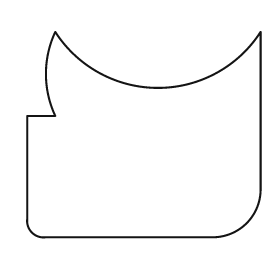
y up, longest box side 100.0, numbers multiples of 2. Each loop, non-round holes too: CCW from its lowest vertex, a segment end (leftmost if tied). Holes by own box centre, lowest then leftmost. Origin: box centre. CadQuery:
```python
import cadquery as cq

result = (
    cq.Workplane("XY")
    .moveTo(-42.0, -44.0)
    .lineTo(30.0, -44.0)
    .threePointArc((44.0, -38.0), (50.0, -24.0))
    .lineTo(50.0, 44.0)
    .threePointArc((6.0, 20.0), (-38.0, 44.0))
    .threePointArc((-42.0, 26.0), (-38.0, 8.0))
    .lineTo(-50.0, 8.0)
    .lineTo(-50.0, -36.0)
    .threePointArc((-48.0, -42.0), (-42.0, -44.0))
    .close()
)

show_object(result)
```